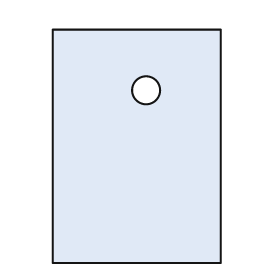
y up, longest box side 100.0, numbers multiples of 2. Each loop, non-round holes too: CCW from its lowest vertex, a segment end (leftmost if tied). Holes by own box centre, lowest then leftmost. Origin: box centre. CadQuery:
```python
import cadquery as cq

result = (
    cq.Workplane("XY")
    .moveTo(-36.0, -50.0)
    .lineTo(36.0, -50.0)
    .lineTo(36.0, 50.0)
    .lineTo(-36.0, 50.0)
    .close()
    .moveTo(4.0, 24.0)
    .circle(6.0)
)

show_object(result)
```